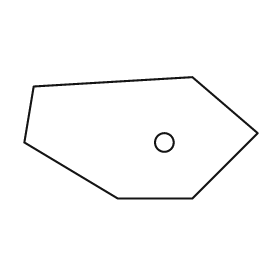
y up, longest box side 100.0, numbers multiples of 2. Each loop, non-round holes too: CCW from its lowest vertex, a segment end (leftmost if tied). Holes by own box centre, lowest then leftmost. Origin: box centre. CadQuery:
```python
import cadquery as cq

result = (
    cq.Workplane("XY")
    .moveTo(-10.0, -26.0)
    .lineTo(22.0, -26.0)
    .lineTo(50.0, 2.0)
    .lineTo(22.0, 26.0)
    .lineTo(-46.0, 22.0)
    .lineTo(-50.0, -2.0)
    .close()
    .moveTo(10.0, -2.0)
    .circle(4.0)
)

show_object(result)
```